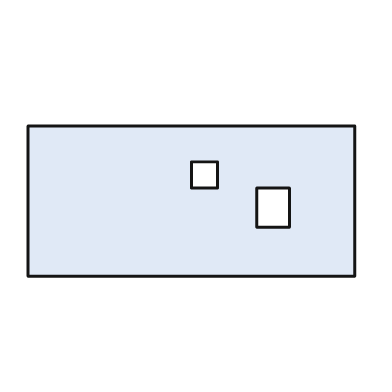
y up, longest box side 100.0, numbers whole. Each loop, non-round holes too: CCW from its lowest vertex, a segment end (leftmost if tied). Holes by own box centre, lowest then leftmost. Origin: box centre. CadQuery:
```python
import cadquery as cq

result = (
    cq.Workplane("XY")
    .moveTo(-50.0, -23.0)
    .lineTo(50.0, -23.0)
    .lineTo(50.0, 23.0)
    .lineTo(-50.0, 23.0)
    .close()
    .moveTo(20.0, -8.0)
    .lineTo(30.0, -8.0)
    .lineTo(30.0, 4.0)
    .lineTo(20.0, 4.0)
    .close()
    .moveTo(0.0, 4.0)
    .lineTo(8.0, 4.0)
    .lineTo(8.0, 12.0)
    .lineTo(0.0, 12.0)
    .close()
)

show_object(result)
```